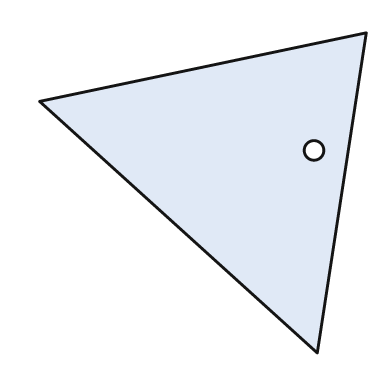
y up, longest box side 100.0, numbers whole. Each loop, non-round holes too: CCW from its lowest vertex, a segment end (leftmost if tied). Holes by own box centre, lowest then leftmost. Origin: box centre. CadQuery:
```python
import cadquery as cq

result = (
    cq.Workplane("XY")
    .moveTo(35.0, -49.0)
    .lineTo(50.0, 49.0)
    .lineTo(-50.0, 28.0)
    .close()
    .moveTo(34.0, 13.0)
    .circle(3.0)
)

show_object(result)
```